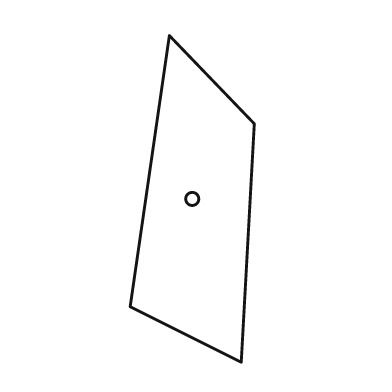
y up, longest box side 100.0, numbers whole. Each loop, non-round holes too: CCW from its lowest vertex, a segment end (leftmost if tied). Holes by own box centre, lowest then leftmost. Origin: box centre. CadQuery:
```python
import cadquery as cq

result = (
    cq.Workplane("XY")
    .moveTo(15.0, -50.0)
    .lineTo(19.0, 23.0)
    .lineTo(-7.0, 50.0)
    .lineTo(-19.0, -33.0)
    .close()
    .moveTo(0.0, 0.0)
    .circle(2.0)
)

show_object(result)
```